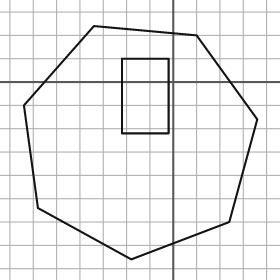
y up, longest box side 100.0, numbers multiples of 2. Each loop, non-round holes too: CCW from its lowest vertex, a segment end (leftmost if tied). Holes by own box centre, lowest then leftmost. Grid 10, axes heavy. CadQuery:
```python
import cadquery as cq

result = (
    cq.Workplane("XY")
    .moveTo(-18.0, -76.0)
    .lineTo(24.0, -60.0)
    .lineTo(36.0, -16.0)
    .lineTo(10.0, 20.0)
    .lineTo(-34.0, 24.0)
    .lineTo(-64.0, -10.0)
    .lineTo(-58.0, -54.0)
    .close()
    .moveTo(-22.0, -22.0)
    .lineTo(-2.0, -22.0)
    .lineTo(-2.0, 10.0)
    .lineTo(-22.0, 10.0)
    .close()
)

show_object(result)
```